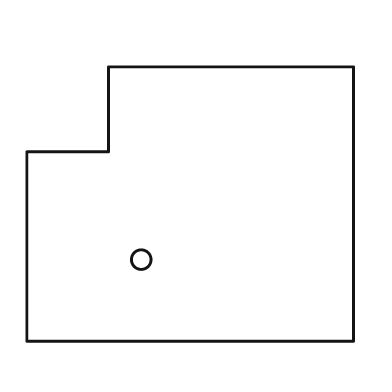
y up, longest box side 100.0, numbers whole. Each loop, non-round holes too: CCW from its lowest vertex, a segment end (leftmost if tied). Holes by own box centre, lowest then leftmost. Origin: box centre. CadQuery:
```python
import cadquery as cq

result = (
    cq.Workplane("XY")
    .moveTo(-50.0, -42.0)
    .lineTo(50.0, -42.0)
    .lineTo(50.0, 42.0)
    .lineTo(-25.0, 42.0)
    .lineTo(-25.0, 16.0)
    .lineTo(-50.0, 16.0)
    .close()
    .moveTo(-15.0, -17.0)
    .circle(3.0)
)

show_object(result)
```